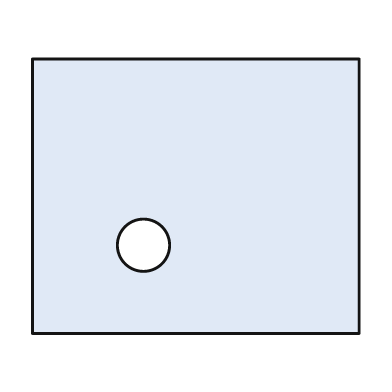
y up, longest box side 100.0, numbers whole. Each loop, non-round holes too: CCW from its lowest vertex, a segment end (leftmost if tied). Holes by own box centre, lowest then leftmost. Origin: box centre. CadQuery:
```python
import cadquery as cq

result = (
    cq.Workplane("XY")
    .moveTo(-50.0, -42.0)
    .lineTo(50.0, -42.0)
    .lineTo(50.0, 42.0)
    .lineTo(-50.0, 42.0)
    .close()
    .moveTo(-16.0, -15.0)
    .circle(8.0)
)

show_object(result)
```